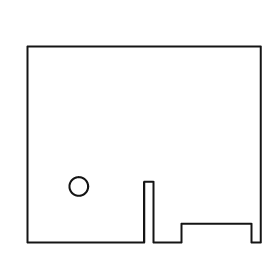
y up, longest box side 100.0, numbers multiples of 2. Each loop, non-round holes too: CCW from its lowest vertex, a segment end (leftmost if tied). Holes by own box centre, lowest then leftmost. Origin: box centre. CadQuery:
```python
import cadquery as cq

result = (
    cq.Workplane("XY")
    .moveTo(-50.0, -42.0)
    .lineTo(0.0, -42.0)
    .lineTo(0.0, -16.0)
    .lineTo(4.0, -16.0)
    .lineTo(4.0, -42.0)
    .lineTo(16.0, -42.0)
    .lineTo(16.0, -34.0)
    .lineTo(46.0, -34.0)
    .lineTo(46.0, -42.0)
    .lineTo(50.0, -42.0)
    .lineTo(50.0, 42.0)
    .lineTo(-50.0, 42.0)
    .close()
    .moveTo(-28.0, -18.0)
    .circle(4.0)
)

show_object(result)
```